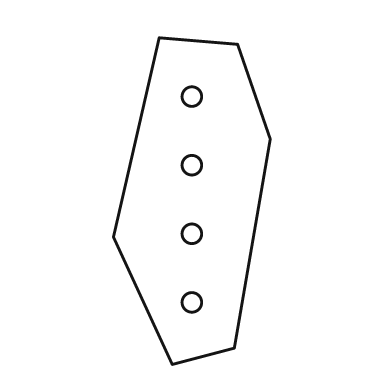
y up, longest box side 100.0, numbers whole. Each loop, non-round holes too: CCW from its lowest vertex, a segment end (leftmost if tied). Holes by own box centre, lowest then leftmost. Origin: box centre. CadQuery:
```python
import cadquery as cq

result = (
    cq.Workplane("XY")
    .moveTo(-6.0, -50.0)
    .lineTo(13.0, -45.0)
    .lineTo(24.0, 19.0)
    .lineTo(14.0, 48.0)
    .lineTo(-10.0, 50.0)
    .lineTo(-24.0, -11.0)
    .close()
    .moveTo(0.0, -31.0)
    .circle(3.0)
    .moveTo(0.0, -10.0)
    .circle(3.0)
    .moveTo(0.0, 11.0)
    .circle(3.0)
    .moveTo(0.0, 32.0)
    .circle(3.0)
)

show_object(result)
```